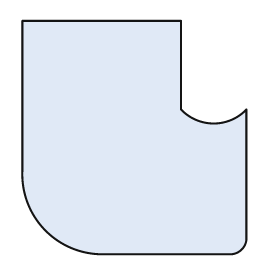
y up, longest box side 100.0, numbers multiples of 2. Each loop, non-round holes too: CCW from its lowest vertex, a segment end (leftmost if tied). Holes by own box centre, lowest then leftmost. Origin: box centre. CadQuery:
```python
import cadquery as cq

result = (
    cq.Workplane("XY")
    .moveTo(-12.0, -50.0)
    .lineTo(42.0, -50.0)
    .threePointArc((46.0, -48.0), (48.0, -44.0))
    .lineTo(48.0, 12.0)
    .threePointArc((34.0, 6.0), (20.0, 12.0))
    .lineTo(20.0, 50.0)
    .lineTo(-48.0, 50.0)
    .lineTo(-48.0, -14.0)
    .threePointArc((-38.0, -40.0), (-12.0, -50.0))
    .close()
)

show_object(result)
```